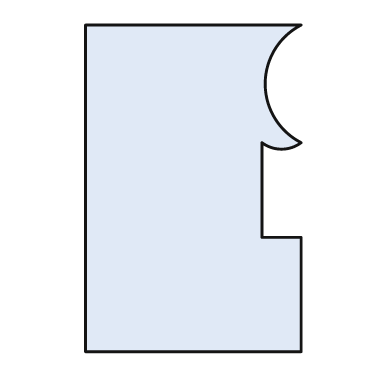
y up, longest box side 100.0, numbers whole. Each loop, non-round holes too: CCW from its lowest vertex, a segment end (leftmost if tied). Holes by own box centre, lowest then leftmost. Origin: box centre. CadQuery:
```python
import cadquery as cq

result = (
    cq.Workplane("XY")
    .moveTo(-33.0, -50.0)
    .lineTo(33.0, -50.0)
    .lineTo(33.0, -15.0)
    .lineTo(21.0, -15.0)
    .lineTo(21.0, 14.0)
    .threePointArc((27.0, 12.0), (33.0, 14.0))
    .threePointArc((22.0, 32.0), (33.0, 50.0))
    .lineTo(-33.0, 50.0)
    .close()
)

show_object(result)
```